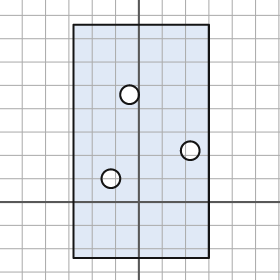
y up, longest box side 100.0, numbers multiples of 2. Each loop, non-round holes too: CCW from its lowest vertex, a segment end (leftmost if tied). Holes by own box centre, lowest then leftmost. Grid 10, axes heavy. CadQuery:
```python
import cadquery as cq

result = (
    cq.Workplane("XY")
    .moveTo(-28.0, -24.0)
    .lineTo(30.0, -24.0)
    .lineTo(30.0, 76.0)
    .lineTo(-28.0, 76.0)
    .close()
    .moveTo(-12.0, 10.0)
    .circle(4.0)
    .moveTo(22.0, 22.0)
    .circle(4.0)
    .moveTo(-4.0, 46.0)
    .circle(4.0)
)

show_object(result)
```